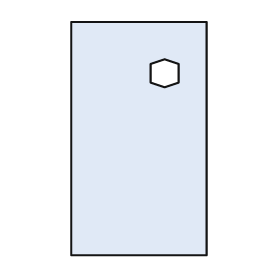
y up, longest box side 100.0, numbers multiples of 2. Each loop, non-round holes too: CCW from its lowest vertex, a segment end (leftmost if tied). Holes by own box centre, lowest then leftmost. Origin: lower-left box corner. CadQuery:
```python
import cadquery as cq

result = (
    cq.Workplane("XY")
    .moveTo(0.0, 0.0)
    .lineTo(58.0, 0.0)
    .lineTo(58.0, 100.0)
    .lineTo(0.0, 100.0)
    .close()
    .moveTo(40.0, 72.0)
    .lineTo(46.0, 74.0)
    .lineTo(46.0, 82.0)
    .lineTo(40.0, 84.0)
    .lineTo(34.0, 82.0)
    .lineTo(34.0, 74.0)
    .close()
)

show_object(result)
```